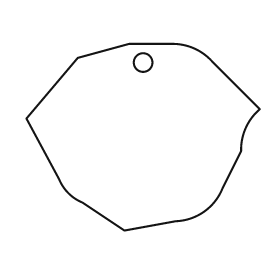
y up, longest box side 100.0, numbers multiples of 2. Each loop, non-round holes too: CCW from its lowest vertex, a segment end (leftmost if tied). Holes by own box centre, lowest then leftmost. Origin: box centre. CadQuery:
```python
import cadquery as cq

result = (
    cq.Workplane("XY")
    .moveTo(-8.0, -40.0)
    .lineTo(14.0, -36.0)
    .threePointArc((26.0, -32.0), (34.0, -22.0))
    .lineTo(42.0, -6.0)
    .threePointArc((44.0, 4.0), (50.0, 12.0))
    .lineTo(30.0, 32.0)
    .threePointArc((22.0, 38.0), (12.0, 40.0))
    .lineTo(-6.0, 40.0)
    .lineTo(-28.0, 34.0)
    .lineTo(-50.0, 8.0)
    .lineTo(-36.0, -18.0)
    .threePointArc((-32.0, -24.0), (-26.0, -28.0))
    .close()
    .moveTo(0.0, 32.0)
    .circle(4.0)
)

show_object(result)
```